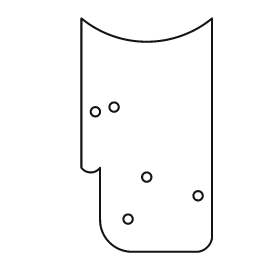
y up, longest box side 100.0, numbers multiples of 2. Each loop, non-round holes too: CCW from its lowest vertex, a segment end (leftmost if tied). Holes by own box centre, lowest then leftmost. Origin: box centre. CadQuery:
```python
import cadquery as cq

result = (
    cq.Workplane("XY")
    .moveTo(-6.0, -50.0)
    .lineTo(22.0, -50.0)
    .threePointArc((26.0, -48.0), (28.0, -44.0))
    .lineTo(28.0, 50.0)
    .threePointArc((0.0, 40.0), (-28.0, 50.0))
    .lineTo(-28.0, -14.0)
    .threePointArc((-24.0, -16.0), (-20.0, -14.0))
    .lineTo(-20.0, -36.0)
    .threePointArc((-16.0, -46.0), (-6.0, -50.0))
    .close()
    .moveTo(-8.0, -36.0)
    .circle(2.0)
    .moveTo(22.0, -26.0)
    .circle(2.0)
    .moveTo(0.0, -18.0)
    .circle(2.0)
    .moveTo(-22.0, 10.0)
    .circle(2.0)
    .moveTo(-14.0, 12.0)
    .circle(2.0)
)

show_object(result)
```